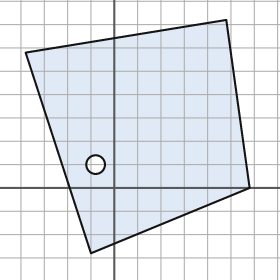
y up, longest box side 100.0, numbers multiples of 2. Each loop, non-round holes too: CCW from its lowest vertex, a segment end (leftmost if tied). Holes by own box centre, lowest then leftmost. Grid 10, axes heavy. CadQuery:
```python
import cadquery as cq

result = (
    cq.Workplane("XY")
    .moveTo(-10.0, -28.0)
    .lineTo(58.0, 0.0)
    .lineTo(48.0, 72.0)
    .lineTo(-38.0, 58.0)
    .close()
    .moveTo(-8.0, 10.0)
    .circle(4.0)
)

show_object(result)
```